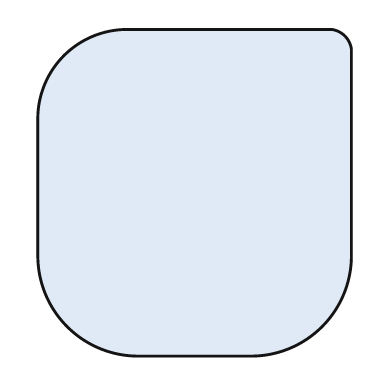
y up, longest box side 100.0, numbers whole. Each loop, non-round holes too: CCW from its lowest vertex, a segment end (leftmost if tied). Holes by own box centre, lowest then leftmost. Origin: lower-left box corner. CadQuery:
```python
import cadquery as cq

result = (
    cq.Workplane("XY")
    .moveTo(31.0, 0.0)
    .lineTo(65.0, 0.0)
    .threePointArc((87.0, 9.0), (96.0, 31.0))
    .lineTo(96.0, 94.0)
    .threePointArc((94.0, 98.0), (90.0, 100.0))
    .lineTo(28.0, 100.0)
    .threePointArc((8.0, 92.0), (0.0, 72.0))
    .lineTo(0.0, 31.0)
    .threePointArc((9.0, 9.0), (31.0, 0.0))
    .close()
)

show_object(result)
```